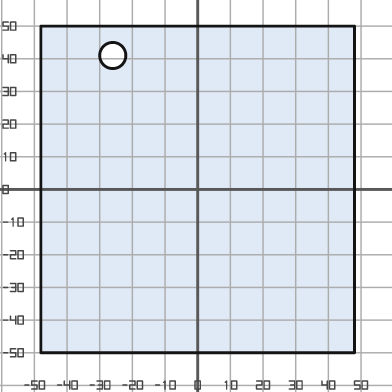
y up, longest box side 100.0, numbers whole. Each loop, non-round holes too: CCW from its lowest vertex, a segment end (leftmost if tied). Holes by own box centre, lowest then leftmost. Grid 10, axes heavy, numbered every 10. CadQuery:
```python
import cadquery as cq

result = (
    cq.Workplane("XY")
    .moveTo(-48.0, -50.0)
    .lineTo(48.0, -50.0)
    .lineTo(48.0, 50.0)
    .lineTo(-48.0, 50.0)
    .close()
    .moveTo(-26.0, 41.0)
    .circle(4.0)
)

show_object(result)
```